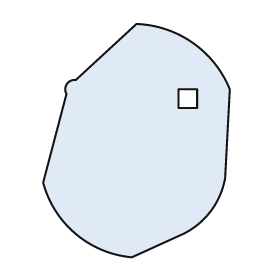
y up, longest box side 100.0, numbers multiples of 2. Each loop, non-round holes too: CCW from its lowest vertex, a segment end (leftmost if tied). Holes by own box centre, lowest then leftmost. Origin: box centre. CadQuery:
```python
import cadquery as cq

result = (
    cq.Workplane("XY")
    .moveTo(-2.0, -50.0)
    .lineTo(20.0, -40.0)
    .threePointArc((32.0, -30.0), (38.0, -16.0))
    .lineTo(40.0, 22.0)
    .threePointArc((24.0, 42.0), (0.0, 50.0))
    .lineTo(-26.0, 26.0)
    .threePointArc((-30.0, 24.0), (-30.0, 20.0))
    .lineTo(-40.0, -18.0)
    .threePointArc((-26.0, -40.0), (-2.0, -50.0))
    .close()
    .moveTo(18.0, 14.0)
    .lineTo(26.0, 14.0)
    .lineTo(26.0, 22.0)
    .lineTo(18.0, 22.0)
    .close()
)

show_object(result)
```